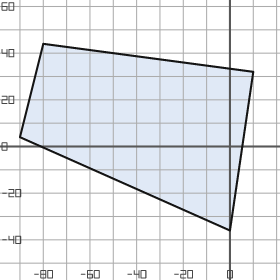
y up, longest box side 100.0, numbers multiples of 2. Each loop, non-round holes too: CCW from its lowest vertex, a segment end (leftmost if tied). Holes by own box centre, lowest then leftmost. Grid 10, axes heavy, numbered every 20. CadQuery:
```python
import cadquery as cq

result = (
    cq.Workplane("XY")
    .moveTo(0.0, -36.0)
    .lineTo(10.0, 32.0)
    .lineTo(-80.0, 44.0)
    .lineTo(-90.0, 4.0)
    .close()
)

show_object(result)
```